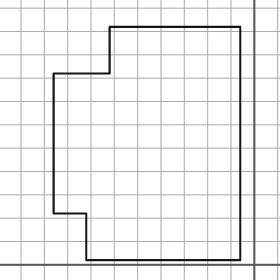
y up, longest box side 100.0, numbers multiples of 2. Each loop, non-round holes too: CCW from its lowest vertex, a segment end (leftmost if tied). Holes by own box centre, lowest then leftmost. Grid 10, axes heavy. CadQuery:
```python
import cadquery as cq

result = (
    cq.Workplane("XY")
    .moveTo(-72.0, 2.0)
    .lineTo(-6.0, 2.0)
    .lineTo(-6.0, 102.0)
    .lineTo(-62.0, 102.0)
    .lineTo(-62.0, 82.0)
    .lineTo(-86.0, 82.0)
    .lineTo(-86.0, 22.0)
    .lineTo(-72.0, 22.0)
    .close()
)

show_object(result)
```